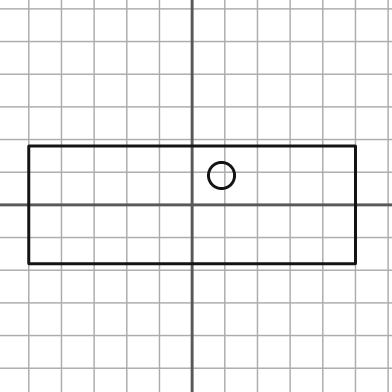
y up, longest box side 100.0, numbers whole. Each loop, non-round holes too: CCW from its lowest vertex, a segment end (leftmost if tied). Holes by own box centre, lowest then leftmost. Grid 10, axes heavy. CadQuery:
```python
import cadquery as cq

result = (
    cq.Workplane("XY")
    .moveTo(-50.0, -18.0)
    .lineTo(50.0, -18.0)
    .lineTo(50.0, 18.0)
    .lineTo(-50.0, 18.0)
    .close()
    .moveTo(9.0, 9.0)
    .circle(4.0)
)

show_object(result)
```